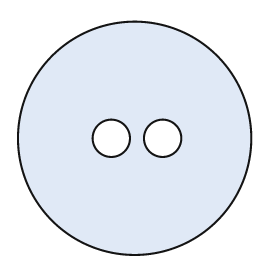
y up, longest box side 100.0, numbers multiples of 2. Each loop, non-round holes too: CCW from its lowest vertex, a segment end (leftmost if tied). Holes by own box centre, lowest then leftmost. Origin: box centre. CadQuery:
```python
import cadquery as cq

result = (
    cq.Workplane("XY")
    .moveTo(0.0, 0.0)
    .circle(50.0)
    .moveTo(-10.0, 0.0)
    .circle(8.0)
    .moveTo(12.0, 0.0)
    .circle(8.0)
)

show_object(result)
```